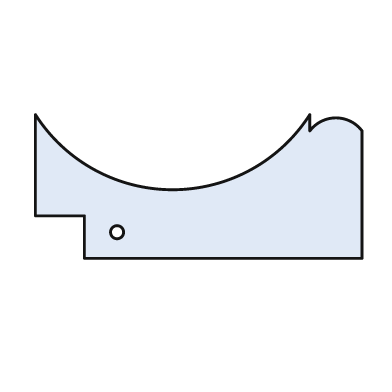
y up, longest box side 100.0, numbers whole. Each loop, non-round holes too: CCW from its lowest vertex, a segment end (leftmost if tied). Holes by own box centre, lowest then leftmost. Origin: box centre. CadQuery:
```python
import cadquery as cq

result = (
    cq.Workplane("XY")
    .moveTo(-35.0, -22.0)
    .lineTo(50.0, -22.0)
    .lineTo(50.0, 17.0)
    .threePointArc((42.0, 21.0), (34.0, 17.0))
    .lineTo(34.0, 22.0)
    .threePointArc((-8.0, -1.0), (-50.0, 22.0))
    .lineTo(-50.0, -9.0)
    .lineTo(-35.0, -9.0)
    .close()
    .moveTo(-25.0, -14.0)
    .circle(2.0)
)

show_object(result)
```